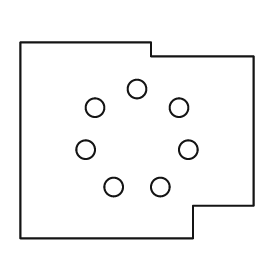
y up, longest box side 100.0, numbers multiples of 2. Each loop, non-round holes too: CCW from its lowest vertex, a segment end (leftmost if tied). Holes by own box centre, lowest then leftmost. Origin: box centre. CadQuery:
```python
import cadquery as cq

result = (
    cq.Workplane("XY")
    .moveTo(-50.0, -42.0)
    .lineTo(24.0, -42.0)
    .lineTo(24.0, -28.0)
    .lineTo(50.0, -28.0)
    .lineTo(50.0, 36.0)
    .lineTo(6.0, 36.0)
    .lineTo(6.0, 42.0)
    .lineTo(-50.0, 42.0)
    .close()
    .moveTo(-10.0, -20.0)
    .circle(4.0)
    .moveTo(10.0, -20.0)
    .circle(4.0)
    .moveTo(-22.0, -4.0)
    .circle(4.0)
    .moveTo(22.0, -4.0)
    .circle(4.0)
    .moveTo(-18.0, 14.0)
    .circle(4.0)
    .moveTo(18.0, 14.0)
    .circle(4.0)
    .moveTo(0.0, 22.0)
    .circle(4.0)
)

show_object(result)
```